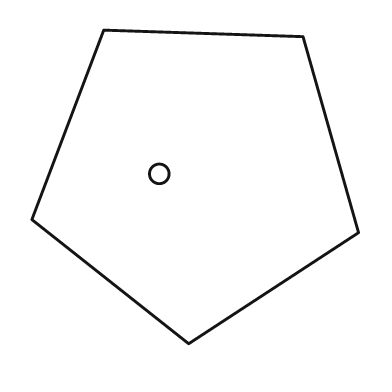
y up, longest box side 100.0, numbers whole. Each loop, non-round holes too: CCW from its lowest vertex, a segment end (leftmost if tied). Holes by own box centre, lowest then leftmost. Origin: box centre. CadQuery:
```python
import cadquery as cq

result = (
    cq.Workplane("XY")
    .moveTo(-2.0, -48.0)
    .lineTo(50.0, -14.0)
    .lineTo(33.0, 46.0)
    .lineTo(-28.0, 48.0)
    .lineTo(-50.0, -10.0)
    .close()
    .moveTo(-11.0, 4.0)
    .circle(3.0)
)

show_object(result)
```